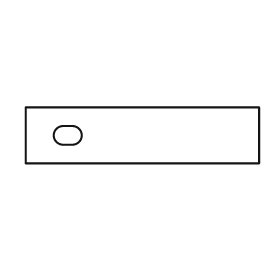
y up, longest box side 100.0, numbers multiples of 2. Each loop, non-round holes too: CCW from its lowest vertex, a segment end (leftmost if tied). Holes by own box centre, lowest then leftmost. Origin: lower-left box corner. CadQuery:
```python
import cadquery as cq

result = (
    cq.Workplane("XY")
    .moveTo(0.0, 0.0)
    .lineTo(100.0, 0.0)
    .lineTo(100.0, 24.0)
    .lineTo(0.0, 24.0)
    .close()
    .moveTo(16.0, 8.0)
    .lineTo(20.0, 8.0)
    .threePointArc((24.0, 12.0), (20.0, 16.0))
    .lineTo(16.0, 16.0)
    .threePointArc((12.0, 12.0), (16.0, 8.0))
    .close()
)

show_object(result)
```